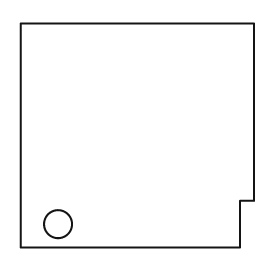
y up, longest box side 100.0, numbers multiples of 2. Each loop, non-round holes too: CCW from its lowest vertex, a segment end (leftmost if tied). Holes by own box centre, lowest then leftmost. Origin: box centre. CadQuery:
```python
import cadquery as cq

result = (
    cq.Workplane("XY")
    .moveTo(-50.0, -48.0)
    .lineTo(44.0, -48.0)
    .lineTo(44.0, -28.0)
    .lineTo(50.0, -28.0)
    .lineTo(50.0, 48.0)
    .lineTo(-50.0, 48.0)
    .close()
    .moveTo(-34.0, -38.0)
    .circle(6.0)
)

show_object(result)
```